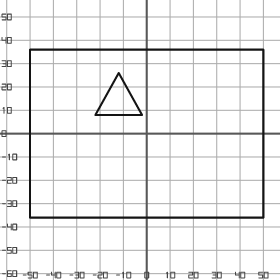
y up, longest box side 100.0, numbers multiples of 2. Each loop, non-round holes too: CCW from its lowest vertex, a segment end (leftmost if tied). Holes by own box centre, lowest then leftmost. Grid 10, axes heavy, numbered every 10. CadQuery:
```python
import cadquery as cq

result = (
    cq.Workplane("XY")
    .moveTo(-50.0, -36.0)
    .lineTo(50.0, -36.0)
    .lineTo(50.0, 36.0)
    .lineTo(-50.0, 36.0)
    .close()
    .moveTo(-22.0, 8.0)
    .lineTo(-2.0, 8.0)
    .lineTo(-12.0, 26.0)
    .close()
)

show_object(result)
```